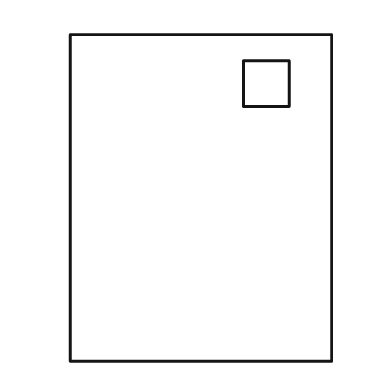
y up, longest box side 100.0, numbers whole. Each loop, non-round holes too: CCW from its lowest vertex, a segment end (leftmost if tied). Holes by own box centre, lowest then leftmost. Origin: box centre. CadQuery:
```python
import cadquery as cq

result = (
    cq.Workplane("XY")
    .moveTo(-40.0, -50.0)
    .lineTo(40.0, -50.0)
    .lineTo(40.0, 50.0)
    .lineTo(-40.0, 50.0)
    .close()
    .moveTo(13.0, 28.0)
    .lineTo(27.0, 28.0)
    .lineTo(27.0, 42.0)
    .lineTo(13.0, 42.0)
    .close()
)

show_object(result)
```